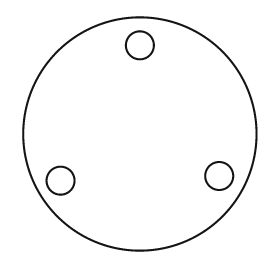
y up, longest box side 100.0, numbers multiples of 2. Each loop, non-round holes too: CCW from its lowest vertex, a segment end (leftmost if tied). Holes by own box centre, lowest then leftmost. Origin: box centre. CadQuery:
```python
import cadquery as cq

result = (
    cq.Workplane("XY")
    .moveTo(0.0, 0.0)
    .circle(50.0)
    .moveTo(-34.0, -20.0)
    .circle(6.0)
    .moveTo(34.0, -18.0)
    .circle(6.0)
    .moveTo(0.0, 38.0)
    .circle(6.0)
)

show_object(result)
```